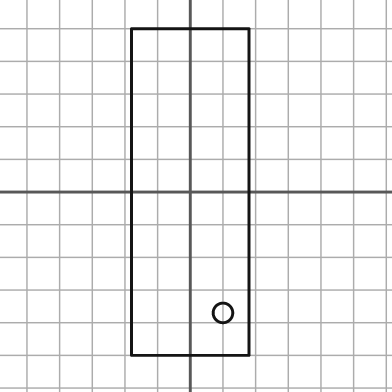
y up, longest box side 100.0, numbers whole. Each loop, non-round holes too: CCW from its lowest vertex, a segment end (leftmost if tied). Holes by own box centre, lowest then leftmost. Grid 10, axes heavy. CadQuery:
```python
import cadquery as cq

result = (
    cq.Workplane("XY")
    .moveTo(-18.0, -50.0)
    .lineTo(18.0, -50.0)
    .lineTo(18.0, 50.0)
    .lineTo(-18.0, 50.0)
    .close()
    .moveTo(10.0, -37.0)
    .circle(3.0)
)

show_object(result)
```